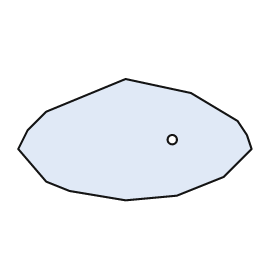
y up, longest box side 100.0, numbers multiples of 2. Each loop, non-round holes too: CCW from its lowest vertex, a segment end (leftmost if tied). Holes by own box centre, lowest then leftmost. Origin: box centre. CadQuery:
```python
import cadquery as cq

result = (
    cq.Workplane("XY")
    .moveTo(-4.0, -26.0)
    .lineTo(18.0, -24.0)
    .lineTo(38.0, -16.0)
    .lineTo(50.0, -4.0)
    .lineTo(48.0, 2.0)
    .lineTo(44.0, 8.0)
    .lineTo(24.0, 20.0)
    .lineTo(-4.0, 26.0)
    .lineTo(-38.0, 12.0)
    .lineTo(-46.0, 4.0)
    .lineTo(-50.0, -4.0)
    .lineTo(-38.0, -18.0)
    .lineTo(-28.0, -22.0)
    .close()
    .moveTo(16.0, 0.0)
    .circle(2.0)
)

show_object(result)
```